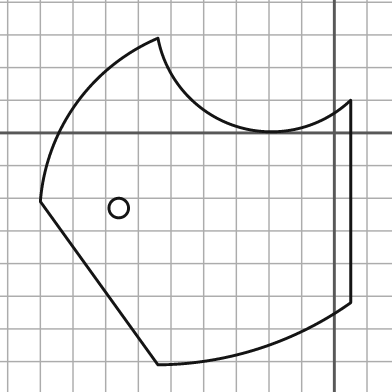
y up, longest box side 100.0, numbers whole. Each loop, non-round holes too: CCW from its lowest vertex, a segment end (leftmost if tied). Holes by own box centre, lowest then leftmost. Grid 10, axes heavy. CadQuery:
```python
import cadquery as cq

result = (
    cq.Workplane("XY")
    .moveTo(-54.0, -71.0)
    .threePointArc((-23.0, -66.0), (5.0, -52.0))
    .lineTo(5.0, 10.0)
    .threePointArc((-30.0, 2.0), (-54.0, 29.0))
    .threePointArc((-79.0, 9.0), (-90.0, -21.0))
    .close()
    .moveTo(-66.0, -23.0)
    .circle(3.0)
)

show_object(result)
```